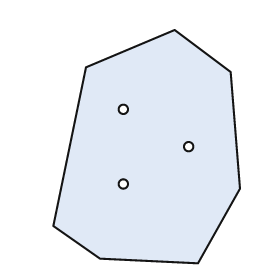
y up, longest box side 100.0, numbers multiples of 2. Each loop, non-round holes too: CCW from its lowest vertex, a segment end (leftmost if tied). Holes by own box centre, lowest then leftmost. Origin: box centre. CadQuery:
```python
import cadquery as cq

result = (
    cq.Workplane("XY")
    .moveTo(22.0, -50.0)
    .lineTo(40.0, -18.0)
    .lineTo(36.0, 32.0)
    .lineTo(12.0, 50.0)
    .lineTo(-26.0, 34.0)
    .lineTo(-40.0, -34.0)
    .lineTo(-20.0, -48.0)
    .close()
    .moveTo(-10.0, -16.0)
    .circle(2.0)
    .moveTo(18.0, 0.0)
    .circle(2.0)
    .moveTo(-10.0, 16.0)
    .circle(2.0)
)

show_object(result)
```